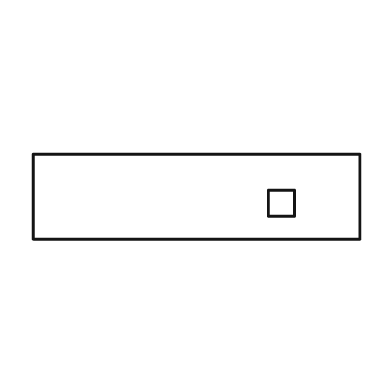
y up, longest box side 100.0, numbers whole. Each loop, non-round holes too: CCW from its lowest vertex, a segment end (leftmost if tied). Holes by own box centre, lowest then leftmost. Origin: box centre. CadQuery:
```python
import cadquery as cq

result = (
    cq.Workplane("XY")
    .moveTo(-50.0, -13.0)
    .lineTo(50.0, -13.0)
    .lineTo(50.0, 13.0)
    .lineTo(-50.0, 13.0)
    .close()
    .moveTo(22.0, -6.0)
    .lineTo(30.0, -6.0)
    .lineTo(30.0, 2.0)
    .lineTo(22.0, 2.0)
    .close()
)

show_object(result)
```